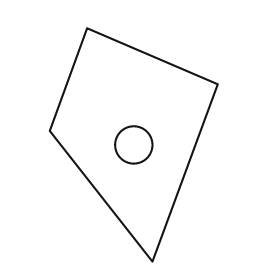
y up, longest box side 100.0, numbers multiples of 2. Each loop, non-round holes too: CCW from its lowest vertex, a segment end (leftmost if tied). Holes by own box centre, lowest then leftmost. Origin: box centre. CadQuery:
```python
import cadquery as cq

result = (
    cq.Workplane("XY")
    .moveTo(8.0, -50.0)
    .lineTo(36.0, 26.0)
    .lineTo(-20.0, 50.0)
    .lineTo(-36.0, 6.0)
    .close()
    .moveTo(0.0, 0.0)
    .circle(8.0)
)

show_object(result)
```